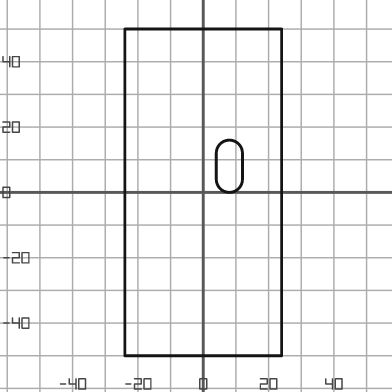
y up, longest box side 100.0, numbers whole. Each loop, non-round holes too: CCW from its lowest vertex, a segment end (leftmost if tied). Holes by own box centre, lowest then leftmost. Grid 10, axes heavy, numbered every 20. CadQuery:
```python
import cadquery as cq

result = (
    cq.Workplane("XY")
    .moveTo(-24.0, -50.0)
    .lineTo(24.0, -50.0)
    .lineTo(24.0, 50.0)
    .lineTo(-24.0, 50.0)
    .close()
    .moveTo(4.0, 4.0)
    .threePointArc((8.0, 0.0), (12.0, 4.0))
    .lineTo(12.0, 12.0)
    .threePointArc((8.0, 16.0), (4.0, 12.0))
    .close()
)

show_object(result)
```